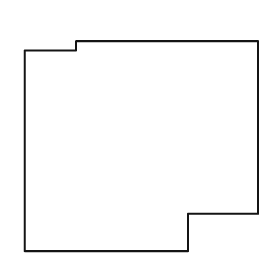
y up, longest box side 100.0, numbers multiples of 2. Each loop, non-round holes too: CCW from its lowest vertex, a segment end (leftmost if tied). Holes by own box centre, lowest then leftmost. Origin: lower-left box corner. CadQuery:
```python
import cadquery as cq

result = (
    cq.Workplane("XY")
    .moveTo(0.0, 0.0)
    .lineTo(70.0, 0.0)
    .lineTo(70.0, 16.0)
    .lineTo(100.0, 16.0)
    .lineTo(100.0, 90.0)
    .lineTo(22.0, 90.0)
    .lineTo(22.0, 86.0)
    .lineTo(0.0, 86.0)
    .close()
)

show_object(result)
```